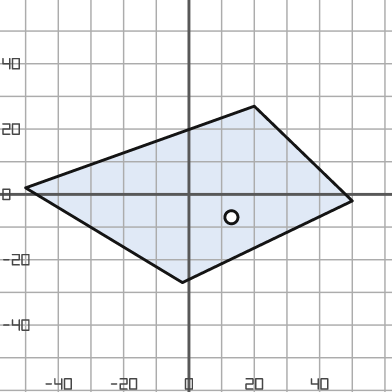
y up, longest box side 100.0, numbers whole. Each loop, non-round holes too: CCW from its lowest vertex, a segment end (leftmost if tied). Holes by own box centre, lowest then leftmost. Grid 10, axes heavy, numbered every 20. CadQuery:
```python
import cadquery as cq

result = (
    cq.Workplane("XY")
    .moveTo(-2.0, -27.0)
    .lineTo(50.0, -2.0)
    .lineTo(20.0, 27.0)
    .lineTo(-50.0, 2.0)
    .close()
    .moveTo(13.0, -7.0)
    .circle(2.0)
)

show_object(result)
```